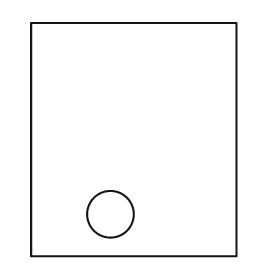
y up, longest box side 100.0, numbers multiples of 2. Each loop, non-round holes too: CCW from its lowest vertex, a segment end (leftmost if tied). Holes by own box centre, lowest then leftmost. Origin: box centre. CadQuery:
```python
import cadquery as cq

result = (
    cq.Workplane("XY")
    .moveTo(-44.0, -50.0)
    .lineTo(44.0, -50.0)
    .lineTo(44.0, 50.0)
    .lineTo(-44.0, 50.0)
    .close()
    .moveTo(-10.0, -32.0)
    .circle(10.0)
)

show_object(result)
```